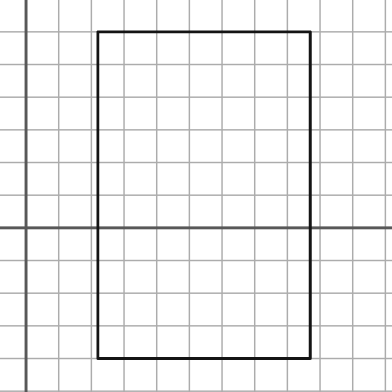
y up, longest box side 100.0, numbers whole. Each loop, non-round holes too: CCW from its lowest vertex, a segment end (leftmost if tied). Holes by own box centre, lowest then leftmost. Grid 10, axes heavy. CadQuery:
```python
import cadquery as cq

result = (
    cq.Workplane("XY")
    .moveTo(22.0, -40.0)
    .lineTo(87.0, -40.0)
    .lineTo(87.0, 60.0)
    .lineTo(22.0, 60.0)
    .close()
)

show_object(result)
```